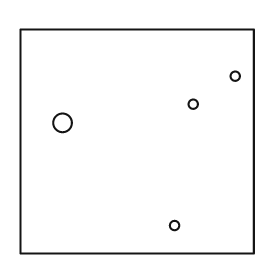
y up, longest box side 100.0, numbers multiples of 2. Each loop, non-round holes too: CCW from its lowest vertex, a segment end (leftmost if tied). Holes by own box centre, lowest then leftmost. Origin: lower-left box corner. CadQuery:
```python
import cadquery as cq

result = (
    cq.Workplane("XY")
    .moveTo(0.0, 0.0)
    .lineTo(100.0, 0.0)
    .lineTo(100.0, 96.0)
    .lineTo(0.0, 96.0)
    .close()
    .moveTo(66.0, 12.0)
    .circle(2.0)
    .moveTo(18.0, 56.0)
    .circle(4.0)
    .moveTo(74.0, 64.0)
    .circle(2.0)
    .moveTo(92.0, 76.0)
    .circle(2.0)
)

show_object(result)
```